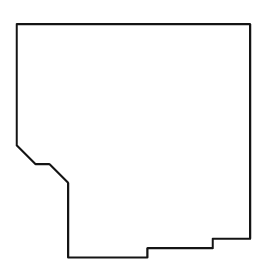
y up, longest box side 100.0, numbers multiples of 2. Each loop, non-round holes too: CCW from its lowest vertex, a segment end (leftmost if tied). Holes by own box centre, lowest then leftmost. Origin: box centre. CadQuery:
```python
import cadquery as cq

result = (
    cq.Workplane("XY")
    .moveTo(-28.0, -50.0)
    .lineTo(6.0, -50.0)
    .lineTo(6.0, -46.0)
    .lineTo(34.0, -46.0)
    .lineTo(34.0, -42.0)
    .lineTo(50.0, -42.0)
    .lineTo(50.0, 50.0)
    .lineTo(-50.0, 50.0)
    .lineTo(-50.0, -2.0)
    .lineTo(-42.0, -10.0)
    .lineTo(-36.0, -10.0)
    .lineTo(-28.0, -18.0)
    .close()
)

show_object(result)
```